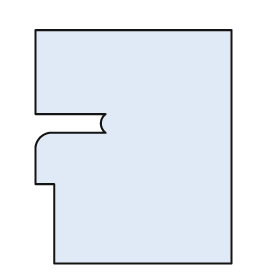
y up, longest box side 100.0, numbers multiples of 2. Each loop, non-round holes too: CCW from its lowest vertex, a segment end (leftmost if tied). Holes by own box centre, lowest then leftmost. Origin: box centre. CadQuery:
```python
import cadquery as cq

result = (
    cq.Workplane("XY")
    .moveTo(-34.0, -50.0)
    .lineTo(42.0, -50.0)
    .lineTo(42.0, 50.0)
    .lineTo(-42.0, 50.0)
    .lineTo(-42.0, 14.0)
    .lineTo(-12.0, 14.0)
    .threePointArc((-14.0, 10.0), (-12.0, 6.0))
    .lineTo(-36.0, 6.0)
    .threePointArc((-40.0, 4.0), (-42.0, 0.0))
    .lineTo(-42.0, -16.0)
    .lineTo(-34.0, -16.0)
    .close()
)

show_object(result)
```